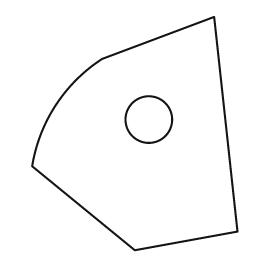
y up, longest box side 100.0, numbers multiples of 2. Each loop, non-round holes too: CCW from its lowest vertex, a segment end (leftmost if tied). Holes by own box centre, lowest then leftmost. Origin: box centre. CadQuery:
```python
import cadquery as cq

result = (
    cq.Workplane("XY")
    .moveTo(0.0, -50.0)
    .lineTo(44.0, -42.0)
    .lineTo(34.0, 50.0)
    .lineTo(-14.0, 32.0)
    .threePointArc((-34.0, 12.0), (-44.0, -14.0))
    .close()
    .moveTo(6.0, 6.0)
    .circle(10.0)
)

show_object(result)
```